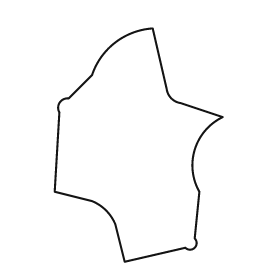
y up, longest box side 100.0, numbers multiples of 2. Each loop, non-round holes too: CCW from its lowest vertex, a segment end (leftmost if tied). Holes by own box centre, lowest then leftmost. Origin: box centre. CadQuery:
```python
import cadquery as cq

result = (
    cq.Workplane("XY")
    .moveTo(-6.0, -50.0)
    .lineTo(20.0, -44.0)
    .threePointArc((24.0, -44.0), (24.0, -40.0))
    .lineTo(26.0, -20.0)
    .threePointArc((24.0, -2.0), (36.0, 12.0))
    .lineTo(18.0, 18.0)
    .threePointArc((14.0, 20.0), (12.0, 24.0))
    .lineTo(6.0, 50.0)
    .threePointArc((-10.0, 44.0), (-20.0, 30.0))
    .lineTo(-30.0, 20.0)
    .threePointArc((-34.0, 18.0), (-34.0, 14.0))
    .lineTo(-36.0, -20.0)
    .lineTo(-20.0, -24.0)
    .threePointArc((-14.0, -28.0), (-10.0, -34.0))
    .close()
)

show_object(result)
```